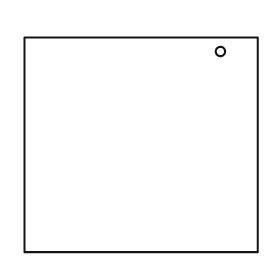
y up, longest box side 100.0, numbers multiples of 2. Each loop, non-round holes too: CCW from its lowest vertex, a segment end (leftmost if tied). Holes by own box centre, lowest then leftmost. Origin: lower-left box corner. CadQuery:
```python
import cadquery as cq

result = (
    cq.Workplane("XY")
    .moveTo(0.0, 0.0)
    .lineTo(100.0, 0.0)
    .lineTo(100.0, 92.0)
    .lineTo(0.0, 92.0)
    .close()
    .moveTo(84.0, 86.0)
    .circle(2.0)
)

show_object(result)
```